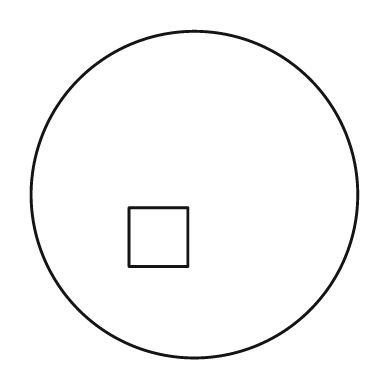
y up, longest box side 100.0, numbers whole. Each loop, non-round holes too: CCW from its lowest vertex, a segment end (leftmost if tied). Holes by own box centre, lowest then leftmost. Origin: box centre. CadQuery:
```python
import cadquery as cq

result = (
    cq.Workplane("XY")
    .moveTo(0.0, 0.0)
    .circle(50.0)
    .moveTo(-20.0, -22.0)
    .lineTo(-2.0, -22.0)
    .lineTo(-2.0, -4.0)
    .lineTo(-20.0, -4.0)
    .close()
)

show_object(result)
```